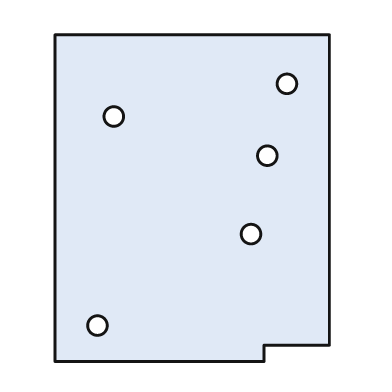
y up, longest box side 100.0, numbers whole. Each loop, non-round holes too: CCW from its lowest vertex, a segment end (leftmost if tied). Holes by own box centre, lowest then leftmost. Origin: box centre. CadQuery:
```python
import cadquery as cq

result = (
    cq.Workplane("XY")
    .moveTo(-42.0, -50.0)
    .lineTo(22.0, -50.0)
    .lineTo(22.0, -45.0)
    .lineTo(42.0, -45.0)
    .lineTo(42.0, 50.0)
    .lineTo(-42.0, 50.0)
    .close()
    .moveTo(-29.0, -39.0)
    .circle(3.0)
    .moveTo(18.0, -11.0)
    .circle(3.0)
    .moveTo(23.0, 13.0)
    .circle(3.0)
    .moveTo(-24.0, 25.0)
    .circle(3.0)
    .moveTo(29.0, 35.0)
    .circle(3.0)
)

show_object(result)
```